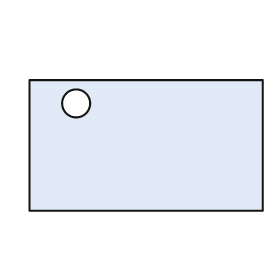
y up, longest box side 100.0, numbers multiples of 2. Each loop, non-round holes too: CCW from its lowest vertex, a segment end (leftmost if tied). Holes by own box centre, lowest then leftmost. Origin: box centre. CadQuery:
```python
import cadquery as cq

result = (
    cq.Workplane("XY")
    .moveTo(-50.0, -28.0)
    .lineTo(50.0, -28.0)
    .lineTo(50.0, 28.0)
    .lineTo(-50.0, 28.0)
    .close()
    .moveTo(-30.0, 18.0)
    .circle(6.0)
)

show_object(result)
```